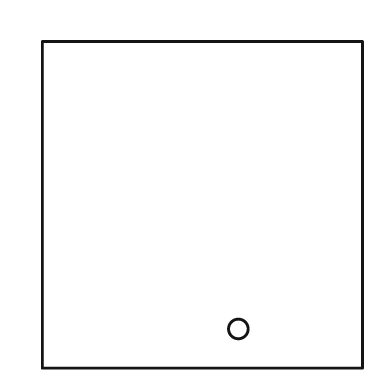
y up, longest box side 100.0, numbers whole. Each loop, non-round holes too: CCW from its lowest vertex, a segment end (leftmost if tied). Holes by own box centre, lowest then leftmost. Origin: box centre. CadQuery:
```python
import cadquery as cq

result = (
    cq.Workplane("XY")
    .moveTo(-49.0, -50.0)
    .lineTo(49.0, -50.0)
    .lineTo(49.0, 50.0)
    .lineTo(-49.0, 50.0)
    .close()
    .moveTo(11.0, -38.0)
    .circle(3.0)
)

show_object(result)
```